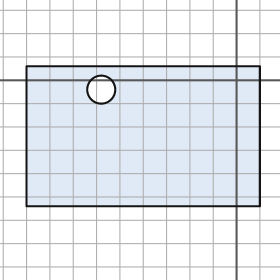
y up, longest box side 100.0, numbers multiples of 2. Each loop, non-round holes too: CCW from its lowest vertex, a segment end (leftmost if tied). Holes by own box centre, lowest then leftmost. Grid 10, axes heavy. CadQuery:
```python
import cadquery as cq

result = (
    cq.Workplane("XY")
    .moveTo(-90.0, -54.0)
    .lineTo(10.0, -54.0)
    .lineTo(10.0, 6.0)
    .lineTo(-90.0, 6.0)
    .close()
    .moveTo(-58.0, -4.0)
    .circle(6.0)
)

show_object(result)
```